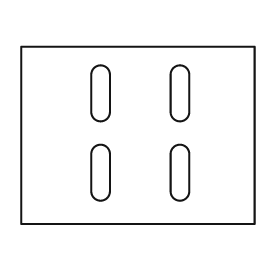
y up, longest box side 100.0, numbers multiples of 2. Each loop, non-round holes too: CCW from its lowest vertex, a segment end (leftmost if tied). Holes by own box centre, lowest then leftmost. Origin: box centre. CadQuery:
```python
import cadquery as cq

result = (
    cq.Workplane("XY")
    .moveTo(-50.0, -38.0)
    .lineTo(50.0, -38.0)
    .lineTo(50.0, 38.0)
    .lineTo(-50.0, 38.0)
    .close()
    .moveTo(-20.0, -24.0)
    .threePointArc((-16.0, -28.0), (-12.0, -24.0))
    .lineTo(-12.0, -8.0)
    .threePointArc((-16.0, -4.0), (-20.0, -8.0))
    .close()
    .moveTo(14.0, -24.0)
    .threePointArc((18.0, -28.0), (22.0, -24.0))
    .lineTo(22.0, -8.0)
    .threePointArc((18.0, -4.0), (14.0, -8.0))
    .close()
    .moveTo(-20.0, 10.0)
    .threePointArc((-16.0, 6.0), (-12.0, 10.0))
    .lineTo(-12.0, 26.0)
    .threePointArc((-16.0, 30.0), (-20.0, 26.0))
    .close()
    .moveTo(14.0, 10.0)
    .threePointArc((18.0, 6.0), (22.0, 10.0))
    .lineTo(22.0, 26.0)
    .threePointArc((18.0, 30.0), (14.0, 26.0))
    .close()
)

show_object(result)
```